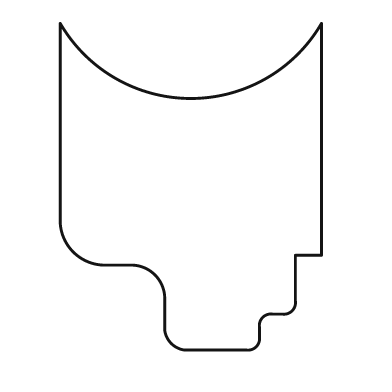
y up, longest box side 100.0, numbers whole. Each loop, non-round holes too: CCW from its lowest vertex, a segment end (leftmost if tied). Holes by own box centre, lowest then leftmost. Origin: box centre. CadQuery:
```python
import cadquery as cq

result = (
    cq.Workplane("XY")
    .moveTo(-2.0, -50.0)
    .lineTo(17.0, -50.0)
    .threePointArc((20.0, -49.0), (21.0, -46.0))
    .lineTo(21.0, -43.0)
    .threePointArc((22.0, -40.0), (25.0, -39.0))
    .lineTo(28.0, -39.0)
    .threePointArc((31.0, -38.0), (32.0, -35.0))
    .lineTo(32.0, -21.0)
    .lineTo(40.0, -21.0)
    .lineTo(40.0, 50.0)
    .threePointArc((0.0, 27.0), (-40.0, 50.0))
    .lineTo(-40.0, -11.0)
    .threePointArc((-36.0, -20.0), (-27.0, -24.0))
    .lineTo(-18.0, -24.0)
    .threePointArc((-11.0, -27.0), (-8.0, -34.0))
    .lineTo(-8.0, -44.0)
    .threePointArc((-6.0, -48.0), (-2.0, -50.0))
    .close()
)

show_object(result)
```